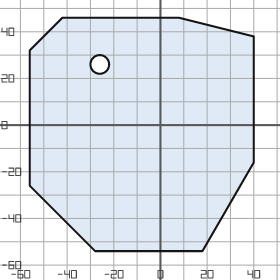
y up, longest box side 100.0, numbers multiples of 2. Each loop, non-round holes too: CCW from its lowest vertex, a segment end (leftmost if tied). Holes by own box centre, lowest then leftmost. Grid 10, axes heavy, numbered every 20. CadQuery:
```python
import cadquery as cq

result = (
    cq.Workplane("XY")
    .moveTo(-28.0, -54.0)
    .lineTo(18.0, -54.0)
    .lineTo(40.0, -16.0)
    .lineTo(40.0, 38.0)
    .lineTo(8.0, 46.0)
    .lineTo(-42.0, 46.0)
    .lineTo(-56.0, 32.0)
    .lineTo(-56.0, -26.0)
    .close()
    .moveTo(-26.0, 26.0)
    .circle(4.0)
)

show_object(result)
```